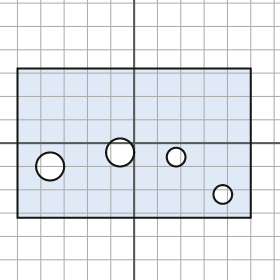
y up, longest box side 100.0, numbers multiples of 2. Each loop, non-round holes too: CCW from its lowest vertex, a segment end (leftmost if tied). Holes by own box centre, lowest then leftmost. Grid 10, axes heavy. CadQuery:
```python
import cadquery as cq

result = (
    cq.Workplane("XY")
    .moveTo(-50.0, -32.0)
    .lineTo(50.0, -32.0)
    .lineTo(50.0, 32.0)
    .lineTo(-50.0, 32.0)
    .close()
    .moveTo(38.0, -22.0)
    .circle(4.0)
    .moveTo(-36.0, -10.0)
    .circle(6.0)
    .moveTo(18.0, -6.0)
    .circle(4.0)
    .moveTo(-6.0, -4.0)
    .circle(6.0)
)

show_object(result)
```